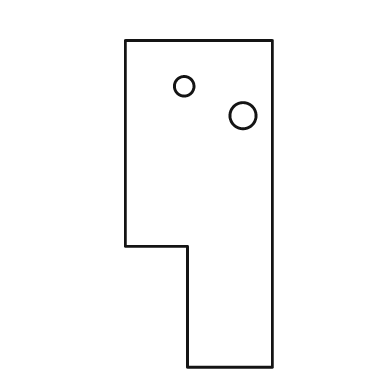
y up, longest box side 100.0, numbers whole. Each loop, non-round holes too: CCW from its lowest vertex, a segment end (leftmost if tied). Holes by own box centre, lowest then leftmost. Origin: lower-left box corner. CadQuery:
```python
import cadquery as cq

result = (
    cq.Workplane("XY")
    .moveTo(19.0, 0.0)
    .lineTo(45.0, 0.0)
    .lineTo(45.0, 100.0)
    .lineTo(0.0, 100.0)
    .lineTo(0.0, 37.0)
    .lineTo(19.0, 37.0)
    .close()
    .moveTo(36.0, 77.0)
    .circle(4.0)
    .moveTo(18.0, 86.0)
    .circle(3.0)
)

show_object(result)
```